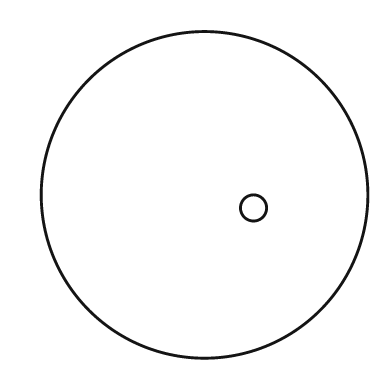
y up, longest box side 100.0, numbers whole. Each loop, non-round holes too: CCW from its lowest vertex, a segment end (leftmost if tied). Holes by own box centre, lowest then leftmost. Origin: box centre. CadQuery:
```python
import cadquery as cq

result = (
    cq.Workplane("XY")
    .moveTo(0.0, 0.0)
    .circle(50.0)
    .moveTo(15.0, -4.0)
    .circle(4.0)
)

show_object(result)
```